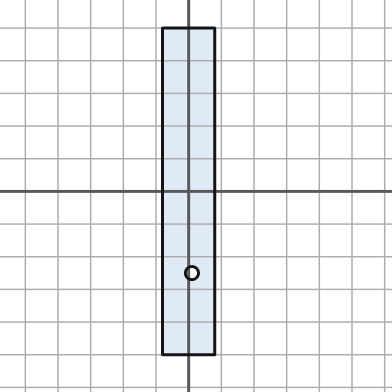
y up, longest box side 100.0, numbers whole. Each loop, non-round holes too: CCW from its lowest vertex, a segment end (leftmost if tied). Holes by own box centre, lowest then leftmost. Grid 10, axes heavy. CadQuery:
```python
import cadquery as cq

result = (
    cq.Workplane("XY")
    .moveTo(-8.0, -50.0)
    .lineTo(8.0, -50.0)
    .lineTo(8.0, 50.0)
    .lineTo(-8.0, 50.0)
    .close()
    .moveTo(1.0, -25.0)
    .circle(2.0)
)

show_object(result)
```